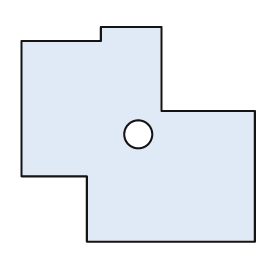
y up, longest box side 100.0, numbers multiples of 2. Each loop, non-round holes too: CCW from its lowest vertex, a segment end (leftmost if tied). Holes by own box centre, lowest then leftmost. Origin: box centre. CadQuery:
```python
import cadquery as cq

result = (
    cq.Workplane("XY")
    .moveTo(-22.0, -46.0)
    .lineTo(50.0, -46.0)
    .lineTo(50.0, 10.0)
    .lineTo(10.0, 10.0)
    .lineTo(10.0, 46.0)
    .lineTo(-16.0, 46.0)
    .lineTo(-16.0, 40.0)
    .lineTo(-50.0, 40.0)
    .lineTo(-50.0, -18.0)
    .lineTo(-22.0, -18.0)
    .close()
    .moveTo(0.0, 0.0)
    .circle(6.0)
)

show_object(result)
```